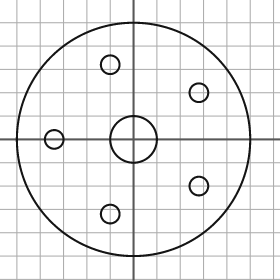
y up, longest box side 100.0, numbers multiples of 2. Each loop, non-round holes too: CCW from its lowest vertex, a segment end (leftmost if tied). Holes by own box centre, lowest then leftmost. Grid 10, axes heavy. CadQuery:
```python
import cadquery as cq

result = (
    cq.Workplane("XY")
    .moveTo(0.0, 0.0)
    .circle(50.0)
    .moveTo(-10.0, -32.0)
    .circle(4.0)
    .moveTo(28.0, -20.0)
    .circle(4.0)
    .moveTo(-34.0, 0.0)
    .circle(4.0)
    .moveTo(0.0, 0.0)
    .circle(10.0)
    .moveTo(28.0, 20.0)
    .circle(4.0)
    .moveTo(-10.0, 32.0)
    .circle(4.0)
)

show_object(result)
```